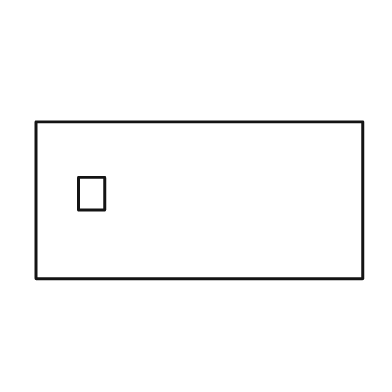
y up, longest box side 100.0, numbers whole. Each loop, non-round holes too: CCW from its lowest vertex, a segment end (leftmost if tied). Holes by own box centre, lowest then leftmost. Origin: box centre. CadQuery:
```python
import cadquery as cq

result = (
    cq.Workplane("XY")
    .moveTo(-50.0, -24.0)
    .lineTo(50.0, -24.0)
    .lineTo(50.0, 24.0)
    .lineTo(-50.0, 24.0)
    .close()
    .moveTo(-37.0, -3.0)
    .lineTo(-29.0, -3.0)
    .lineTo(-29.0, 7.0)
    .lineTo(-37.0, 7.0)
    .close()
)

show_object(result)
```